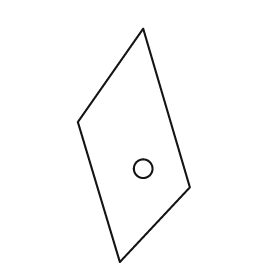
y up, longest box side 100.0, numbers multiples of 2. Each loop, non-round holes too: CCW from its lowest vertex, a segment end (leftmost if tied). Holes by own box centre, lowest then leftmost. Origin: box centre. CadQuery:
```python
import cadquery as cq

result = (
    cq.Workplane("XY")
    .moveTo(-6.0, -50.0)
    .lineTo(24.0, -18.0)
    .lineTo(4.0, 50.0)
    .lineTo(-24.0, 10.0)
    .close()
    .moveTo(4.0, -10.0)
    .circle(4.0)
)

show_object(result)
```